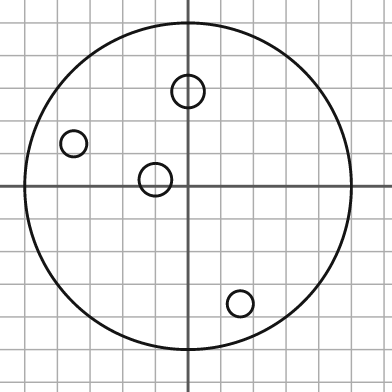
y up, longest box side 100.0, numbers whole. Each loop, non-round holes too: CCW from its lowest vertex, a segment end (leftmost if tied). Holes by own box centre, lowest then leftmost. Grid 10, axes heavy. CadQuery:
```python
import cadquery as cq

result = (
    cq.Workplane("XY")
    .moveTo(0.0, 0.0)
    .circle(50.0)
    .moveTo(16.0, -36.0)
    .circle(4.0)
    .moveTo(-10.0, 2.0)
    .circle(5.0)
    .moveTo(-35.0, 13.0)
    .circle(4.0)
    .moveTo(0.0, 29.0)
    .circle(5.0)
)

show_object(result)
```